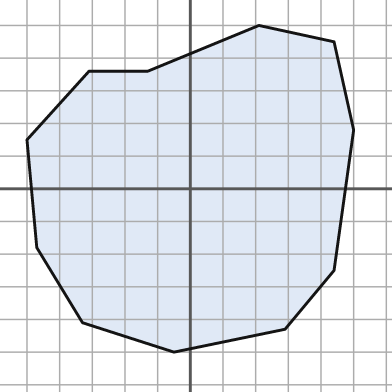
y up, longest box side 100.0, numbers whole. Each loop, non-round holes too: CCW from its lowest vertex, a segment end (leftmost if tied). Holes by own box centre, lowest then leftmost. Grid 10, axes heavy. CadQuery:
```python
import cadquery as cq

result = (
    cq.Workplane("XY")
    .moveTo(-5.0, -50.0)
    .lineTo(29.0, -43.0)
    .lineTo(44.0, -25.0)
    .lineTo(50.0, 18.0)
    .lineTo(44.0, 45.0)
    .lineTo(21.0, 50.0)
    .lineTo(-13.0, 36.0)
    .lineTo(-31.0, 36.0)
    .lineTo(-50.0, 15.0)
    .lineTo(-47.0, -18.0)
    .lineTo(-33.0, -41.0)
    .close()
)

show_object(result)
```